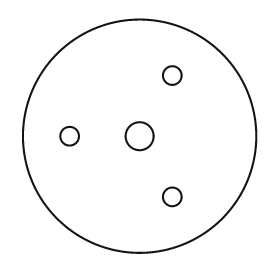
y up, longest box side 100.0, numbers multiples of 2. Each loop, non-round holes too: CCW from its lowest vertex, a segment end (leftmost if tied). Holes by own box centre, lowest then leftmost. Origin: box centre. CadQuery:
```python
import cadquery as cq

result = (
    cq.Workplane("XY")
    .moveTo(0.0, 0.0)
    .circle(50.0)
    .moveTo(14.0, -26.0)
    .circle(4.0)
    .moveTo(-30.0, 0.0)
    .circle(4.0)
    .moveTo(0.0, 0.0)
    .circle(6.0)
    .moveTo(14.0, 26.0)
    .circle(4.0)
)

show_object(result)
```